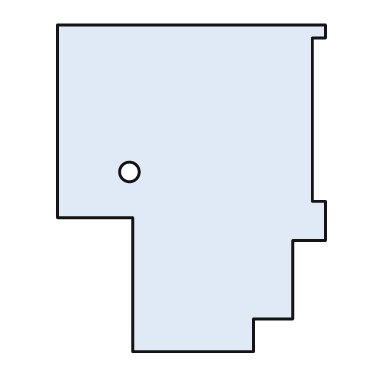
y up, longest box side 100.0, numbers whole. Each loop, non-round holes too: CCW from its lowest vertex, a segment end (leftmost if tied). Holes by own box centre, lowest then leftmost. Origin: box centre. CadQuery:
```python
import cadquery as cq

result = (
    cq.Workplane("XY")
    .moveTo(-18.0, -50.0)
    .lineTo(19.0, -50.0)
    .lineTo(19.0, -40.0)
    .lineTo(31.0, -40.0)
    .lineTo(31.0, -16.0)
    .lineTo(41.0, -16.0)
    .lineTo(41.0, -4.0)
    .lineTo(37.0, -4.0)
    .lineTo(37.0, 46.0)
    .lineTo(41.0, 46.0)
    .lineTo(41.0, 50.0)
    .lineTo(-41.0, 50.0)
    .lineTo(-41.0, -9.0)
    .lineTo(-18.0, -9.0)
    .close()
    .moveTo(-19.0, 5.0)
    .circle(3.0)
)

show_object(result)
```